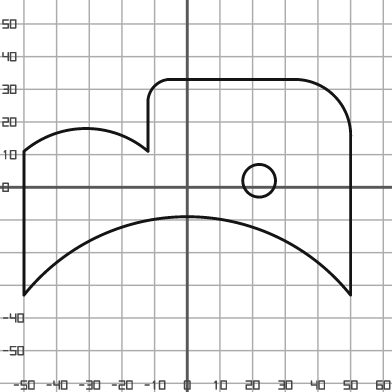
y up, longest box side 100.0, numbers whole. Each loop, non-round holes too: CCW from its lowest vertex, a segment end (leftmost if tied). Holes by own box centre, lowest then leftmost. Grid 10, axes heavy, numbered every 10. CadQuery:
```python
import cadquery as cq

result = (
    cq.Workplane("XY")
    .moveTo(-50.0, -33.0)
    .threePointArc((0.0, -9.0), (50.0, -33.0))
    .lineTo(50.0, 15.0)
    .threePointArc((45.0, 28.0), (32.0, 33.0))
    .lineTo(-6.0, 33.0)
    .threePointArc((-10.0, 31.0), (-12.0, 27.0))
    .lineTo(-12.0, 11.0)
    .threePointArc((-31.0, 18.0), (-50.0, 11.0))
    .close()
    .moveTo(22.0, 2.0)
    .circle(5.0)
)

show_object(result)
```